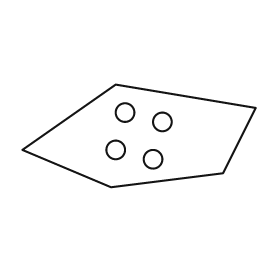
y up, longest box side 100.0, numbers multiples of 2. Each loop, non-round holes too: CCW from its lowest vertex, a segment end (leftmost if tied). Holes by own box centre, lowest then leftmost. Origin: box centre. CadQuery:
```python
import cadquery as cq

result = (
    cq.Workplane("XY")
    .moveTo(-12.0, -22.0)
    .lineTo(36.0, -16.0)
    .lineTo(50.0, 12.0)
    .lineTo(-10.0, 22.0)
    .lineTo(-50.0, -6.0)
    .close()
    .moveTo(6.0, -10.0)
    .circle(4.0)
    .moveTo(-10.0, -6.0)
    .circle(4.0)
    .moveTo(10.0, 6.0)
    .circle(4.0)
    .moveTo(-6.0, 10.0)
    .circle(4.0)
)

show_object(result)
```